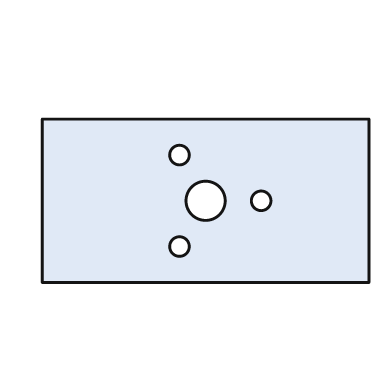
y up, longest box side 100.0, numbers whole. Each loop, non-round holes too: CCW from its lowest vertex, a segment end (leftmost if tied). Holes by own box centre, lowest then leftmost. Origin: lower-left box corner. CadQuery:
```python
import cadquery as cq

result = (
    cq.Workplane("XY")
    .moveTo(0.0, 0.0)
    .lineTo(100.0, 0.0)
    .lineTo(100.0, 50.0)
    .lineTo(0.0, 50.0)
    .close()
    .moveTo(42.0, 11.0)
    .circle(3.0)
    .moveTo(50.0, 25.0)
    .circle(6.0)
    .moveTo(67.0, 25.0)
    .circle(3.0)
    .moveTo(42.0, 39.0)
    .circle(3.0)
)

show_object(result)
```